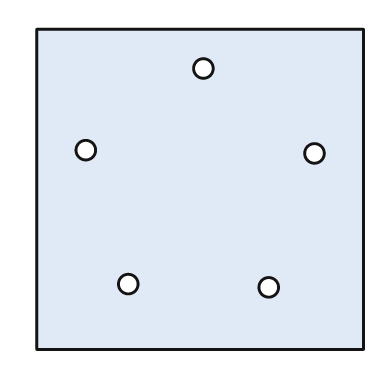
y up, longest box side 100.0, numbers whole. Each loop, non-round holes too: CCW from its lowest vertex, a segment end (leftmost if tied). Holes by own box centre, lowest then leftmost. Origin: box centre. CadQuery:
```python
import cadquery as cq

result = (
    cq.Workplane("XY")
    .moveTo(-50.0, -49.0)
    .lineTo(50.0, -49.0)
    .lineTo(50.0, 49.0)
    .lineTo(-50.0, 49.0)
    .close()
    .moveTo(21.0, -30.0)
    .circle(3.0)
    .moveTo(-22.0, -29.0)
    .circle(3.0)
    .moveTo(35.0, 11.0)
    .circle(3.0)
    .moveTo(-35.0, 12.0)
    .circle(3.0)
    .moveTo(1.0, 37.0)
    .circle(3.0)
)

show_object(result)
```